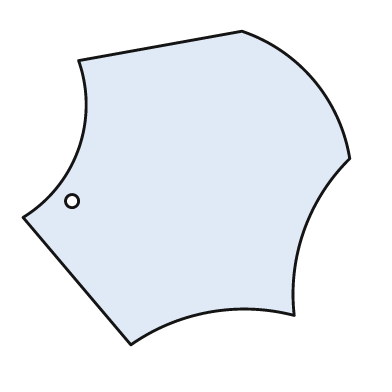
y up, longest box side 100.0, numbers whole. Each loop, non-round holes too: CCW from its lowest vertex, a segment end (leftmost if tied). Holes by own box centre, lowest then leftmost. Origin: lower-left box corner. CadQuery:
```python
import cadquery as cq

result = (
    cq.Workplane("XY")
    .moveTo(33.0, 0.0)
    .threePointArc((57.0, 10.0), (83.0, 9.0))
    .threePointArc((86.0, 35.0), (100.0, 57.0))
    .threePointArc((89.0, 81.0), (67.0, 96.0))
    .lineTo(17.0, 87.0)
    .threePointArc((17.0, 60.0), (0.0, 39.0))
    .close()
    .moveTo(15.0, 44.0)
    .circle(2.0)
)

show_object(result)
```